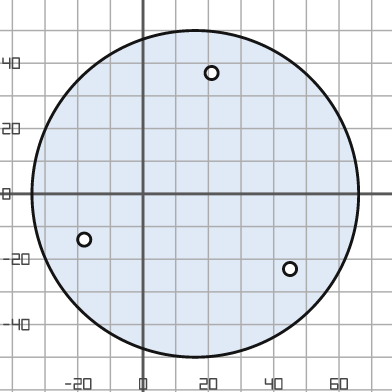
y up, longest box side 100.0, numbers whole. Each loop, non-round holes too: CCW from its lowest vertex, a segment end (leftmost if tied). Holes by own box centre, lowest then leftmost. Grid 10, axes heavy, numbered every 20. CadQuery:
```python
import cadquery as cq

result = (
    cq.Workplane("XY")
    .moveTo(16.0, 0.0)
    .circle(50.0)
    .moveTo(45.0, -23.0)
    .circle(2.0)
    .moveTo(-18.0, -14.0)
    .circle(2.0)
    .moveTo(21.0, 37.0)
    .circle(2.0)
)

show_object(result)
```